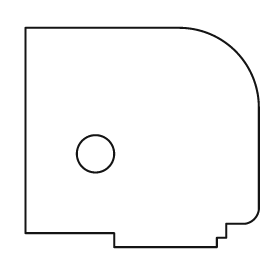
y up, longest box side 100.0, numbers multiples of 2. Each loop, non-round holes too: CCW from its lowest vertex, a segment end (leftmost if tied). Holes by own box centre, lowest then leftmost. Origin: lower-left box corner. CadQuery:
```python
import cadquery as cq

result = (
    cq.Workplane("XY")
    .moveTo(38.0, 0.0)
    .lineTo(82.0, 0.0)
    .lineTo(82.0, 4.0)
    .lineTo(86.0, 4.0)
    .lineTo(86.0, 10.0)
    .lineTo(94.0, 10.0)
    .threePointArc((98.0, 12.0), (100.0, 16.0))
    .lineTo(100.0, 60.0)
    .threePointArc((90.0, 84.0), (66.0, 94.0))
    .lineTo(0.0, 94.0)
    .lineTo(0.0, 6.0)
    .lineTo(38.0, 6.0)
    .close()
    .moveTo(30.0, 40.0)
    .circle(8.0)
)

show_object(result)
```